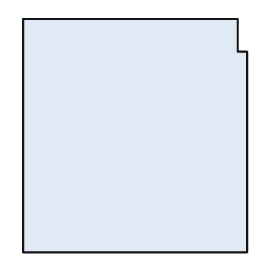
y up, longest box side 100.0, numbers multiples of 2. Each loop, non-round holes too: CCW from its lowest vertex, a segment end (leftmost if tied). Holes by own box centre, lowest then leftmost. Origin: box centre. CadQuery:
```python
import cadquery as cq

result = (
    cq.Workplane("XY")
    .moveTo(-48.0, -50.0)
    .lineTo(48.0, -50.0)
    .lineTo(48.0, 36.0)
    .lineTo(44.0, 36.0)
    .lineTo(44.0, 50.0)
    .lineTo(-48.0, 50.0)
    .close()
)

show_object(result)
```